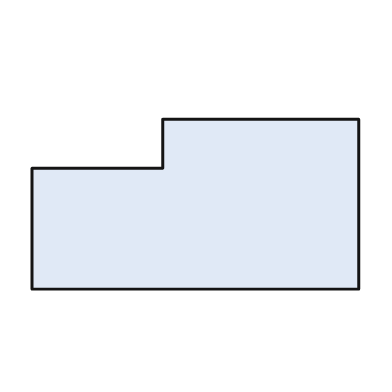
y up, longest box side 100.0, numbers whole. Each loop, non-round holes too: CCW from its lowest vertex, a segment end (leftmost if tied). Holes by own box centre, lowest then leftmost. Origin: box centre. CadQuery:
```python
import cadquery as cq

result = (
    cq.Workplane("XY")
    .moveTo(-50.0, -26.0)
    .lineTo(50.0, -26.0)
    .lineTo(50.0, 26.0)
    .lineTo(-10.0, 26.0)
    .lineTo(-10.0, 11.0)
    .lineTo(-50.0, 11.0)
    .close()
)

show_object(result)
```